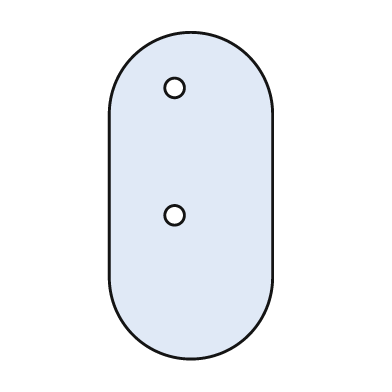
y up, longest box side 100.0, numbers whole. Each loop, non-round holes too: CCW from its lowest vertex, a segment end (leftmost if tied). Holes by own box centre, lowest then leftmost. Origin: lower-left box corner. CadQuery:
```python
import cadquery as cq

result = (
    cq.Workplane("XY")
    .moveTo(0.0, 25.0)
    .threePointArc((25.0, 0.0), (50.0, 25.0))
    .lineTo(50.0, 75.0)
    .threePointArc((25.0, 100.0), (0.0, 75.0))
    .close()
    .moveTo(20.0, 44.0)
    .circle(3.0)
    .moveTo(20.0, 83.0)
    .circle(3.0)
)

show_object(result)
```